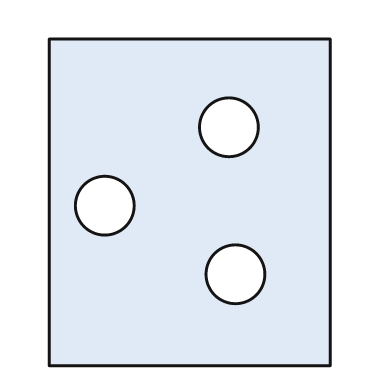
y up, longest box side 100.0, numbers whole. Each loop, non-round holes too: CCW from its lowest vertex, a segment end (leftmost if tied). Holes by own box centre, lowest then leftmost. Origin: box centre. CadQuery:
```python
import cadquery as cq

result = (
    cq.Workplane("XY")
    .moveTo(-43.0, -50.0)
    .lineTo(43.0, -50.0)
    .lineTo(43.0, 50.0)
    .lineTo(-43.0, 50.0)
    .close()
    .moveTo(14.0, -22.0)
    .circle(9.0)
    .moveTo(-26.0, -1.0)
    .circle(9.0)
    .moveTo(12.0, 23.0)
    .circle(9.0)
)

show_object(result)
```